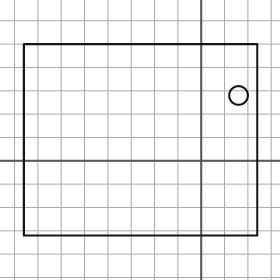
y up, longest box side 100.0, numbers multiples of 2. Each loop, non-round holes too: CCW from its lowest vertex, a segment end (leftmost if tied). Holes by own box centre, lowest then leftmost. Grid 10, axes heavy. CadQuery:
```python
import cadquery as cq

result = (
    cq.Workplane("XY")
    .moveTo(-76.0, -32.0)
    .lineTo(24.0, -32.0)
    .lineTo(24.0, 50.0)
    .lineTo(-76.0, 50.0)
    .close()
    .moveTo(16.0, 28.0)
    .circle(4.0)
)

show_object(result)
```